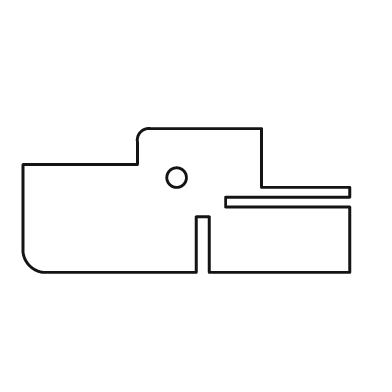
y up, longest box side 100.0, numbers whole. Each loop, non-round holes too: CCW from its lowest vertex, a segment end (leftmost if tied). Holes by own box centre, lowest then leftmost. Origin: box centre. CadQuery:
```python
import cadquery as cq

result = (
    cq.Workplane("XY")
    .moveTo(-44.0, -22.0)
    .lineTo(3.0, -22.0)
    .lineTo(3.0, -5.0)
    .lineTo(7.0, -5.0)
    .lineTo(7.0, -22.0)
    .lineTo(50.0, -22.0)
    .lineTo(50.0, -2.0)
    .lineTo(12.0, -2.0)
    .lineTo(12.0, 1.0)
    .lineTo(50.0, 1.0)
    .lineTo(50.0, 4.0)
    .lineTo(23.0, 4.0)
    .lineTo(23.0, 22.0)
    .lineTo(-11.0, 22.0)
    .threePointArc((-14.0, 21.0), (-15.0, 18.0))
    .lineTo(-15.0, 11.0)
    .lineTo(-50.0, 11.0)
    .lineTo(-50.0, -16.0)
    .threePointArc((-48.0, -20.0), (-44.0, -22.0))
    .close()
    .moveTo(-3.0, 7.0)
    .circle(3.0)
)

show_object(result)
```